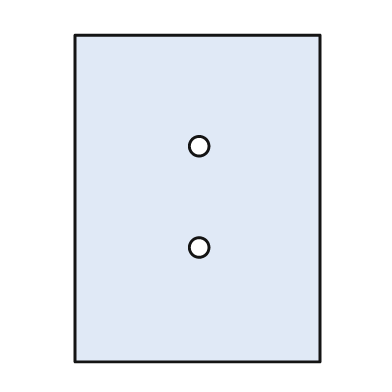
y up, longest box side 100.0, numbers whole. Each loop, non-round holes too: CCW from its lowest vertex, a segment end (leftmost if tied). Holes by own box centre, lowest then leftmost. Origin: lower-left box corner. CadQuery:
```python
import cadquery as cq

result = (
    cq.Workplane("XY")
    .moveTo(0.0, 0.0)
    .lineTo(75.0, 0.0)
    .lineTo(75.0, 100.0)
    .lineTo(0.0, 100.0)
    .close()
    .moveTo(38.0, 35.0)
    .circle(3.0)
    .moveTo(38.0, 66.0)
    .circle(3.0)
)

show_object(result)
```